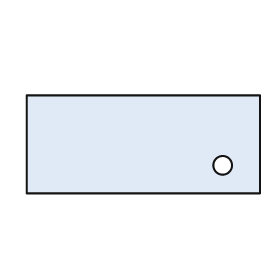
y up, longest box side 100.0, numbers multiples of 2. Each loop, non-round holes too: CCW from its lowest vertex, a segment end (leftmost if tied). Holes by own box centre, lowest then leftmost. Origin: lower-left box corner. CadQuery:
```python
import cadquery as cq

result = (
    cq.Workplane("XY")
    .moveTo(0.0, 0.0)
    .lineTo(100.0, 0.0)
    .lineTo(100.0, 42.0)
    .lineTo(0.0, 42.0)
    .close()
    .moveTo(84.0, 12.0)
    .circle(4.0)
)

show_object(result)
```